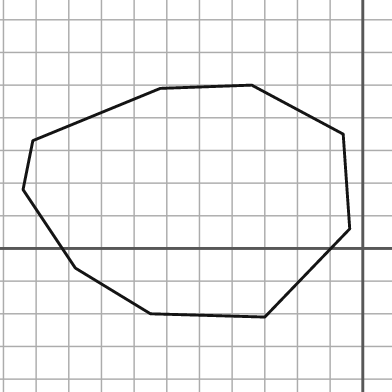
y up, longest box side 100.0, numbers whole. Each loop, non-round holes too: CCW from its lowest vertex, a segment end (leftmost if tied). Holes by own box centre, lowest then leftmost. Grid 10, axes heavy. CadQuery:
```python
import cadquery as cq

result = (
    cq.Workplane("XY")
    .moveTo(-30.0, -21.0)
    .lineTo(-4.0, 6.0)
    .lineTo(-6.0, 35.0)
    .lineTo(-34.0, 50.0)
    .lineTo(-62.0, 49.0)
    .lineTo(-101.0, 33.0)
    .lineTo(-104.0, 18.0)
    .lineTo(-88.0, -6.0)
    .lineTo(-65.0, -20.0)
    .close()
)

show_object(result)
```